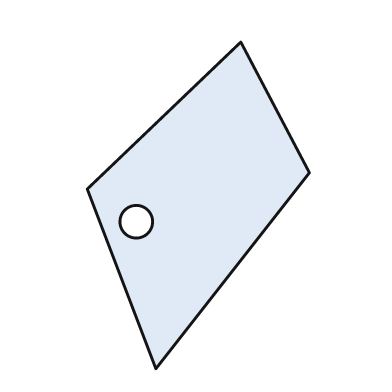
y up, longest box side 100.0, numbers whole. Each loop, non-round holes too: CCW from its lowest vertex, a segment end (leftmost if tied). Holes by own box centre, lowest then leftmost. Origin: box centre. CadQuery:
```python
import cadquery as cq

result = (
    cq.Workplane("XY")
    .moveTo(-13.0, -50.0)
    .lineTo(34.0, 10.0)
    .lineTo(13.0, 50.0)
    .lineTo(-34.0, 5.0)
    .close()
    .moveTo(-19.0, -5.0)
    .circle(5.0)
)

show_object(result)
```